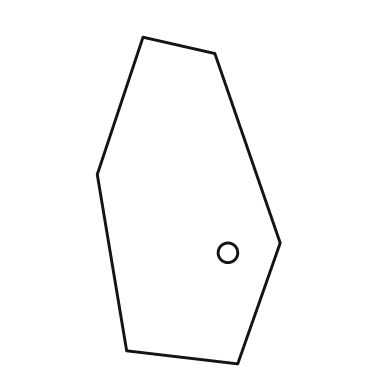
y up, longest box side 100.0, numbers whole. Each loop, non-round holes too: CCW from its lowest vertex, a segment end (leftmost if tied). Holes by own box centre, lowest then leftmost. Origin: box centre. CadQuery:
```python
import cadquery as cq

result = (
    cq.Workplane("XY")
    .moveTo(15.0, -50.0)
    .lineTo(28.0, -13.0)
    .lineTo(8.0, 45.0)
    .lineTo(-14.0, 50.0)
    .lineTo(-28.0, 8.0)
    .lineTo(-19.0, -46.0)
    .close()
    .moveTo(12.0, -16.0)
    .circle(3.0)
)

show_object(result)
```